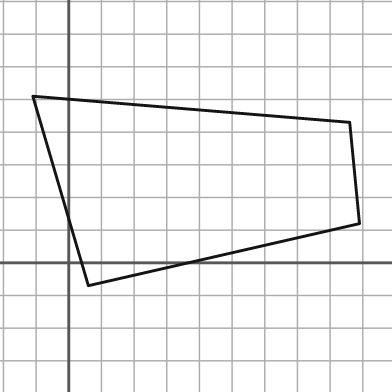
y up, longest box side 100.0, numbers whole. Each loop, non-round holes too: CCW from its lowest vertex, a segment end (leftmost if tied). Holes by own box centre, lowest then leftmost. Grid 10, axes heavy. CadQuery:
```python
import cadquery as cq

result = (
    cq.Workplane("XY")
    .moveTo(6.0, -7.0)
    .lineTo(89.0, 12.0)
    .lineTo(86.0, 43.0)
    .lineTo(-11.0, 51.0)
    .close()
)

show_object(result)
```